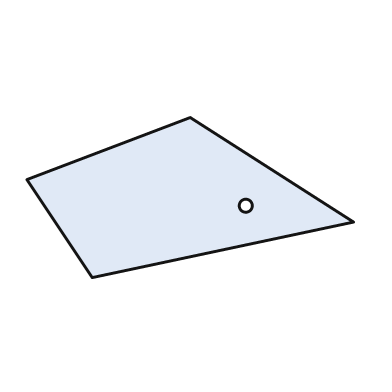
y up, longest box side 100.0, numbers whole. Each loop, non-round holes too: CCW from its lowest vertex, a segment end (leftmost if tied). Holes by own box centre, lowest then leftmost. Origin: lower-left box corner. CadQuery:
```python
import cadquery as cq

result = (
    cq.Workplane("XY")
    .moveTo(20.0, 0.0)
    .lineTo(100.0, 17.0)
    .lineTo(50.0, 49.0)
    .lineTo(0.0, 30.0)
    .close()
    .moveTo(67.0, 22.0)
    .circle(2.0)
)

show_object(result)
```